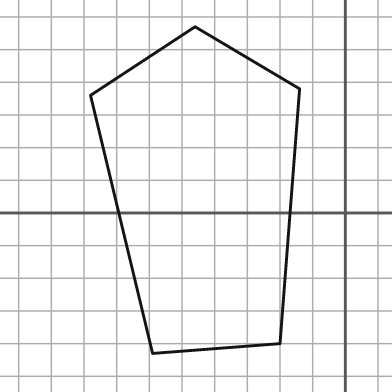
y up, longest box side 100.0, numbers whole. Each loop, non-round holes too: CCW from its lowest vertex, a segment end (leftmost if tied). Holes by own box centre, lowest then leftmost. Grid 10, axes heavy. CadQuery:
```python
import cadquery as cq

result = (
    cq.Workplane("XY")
    .moveTo(-59.0, -43.0)
    .lineTo(-20.0, -40.0)
    .lineTo(-14.0, 38.0)
    .lineTo(-46.0, 57.0)
    .lineTo(-78.0, 36.0)
    .close()
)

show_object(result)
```